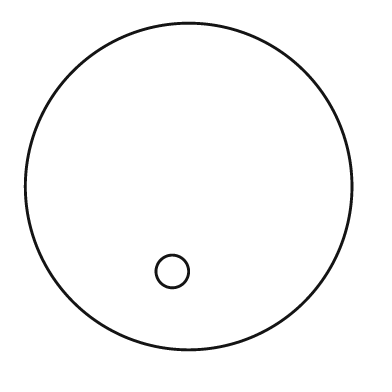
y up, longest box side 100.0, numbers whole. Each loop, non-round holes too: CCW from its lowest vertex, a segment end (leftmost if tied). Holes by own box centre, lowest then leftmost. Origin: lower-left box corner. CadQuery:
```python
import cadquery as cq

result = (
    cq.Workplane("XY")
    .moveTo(50.0, 50.0)
    .circle(50.0)
    .moveTo(45.0, 24.0)
    .circle(5.0)
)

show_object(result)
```